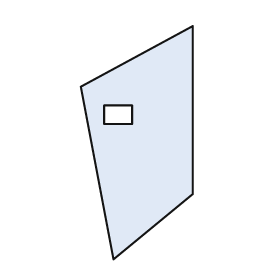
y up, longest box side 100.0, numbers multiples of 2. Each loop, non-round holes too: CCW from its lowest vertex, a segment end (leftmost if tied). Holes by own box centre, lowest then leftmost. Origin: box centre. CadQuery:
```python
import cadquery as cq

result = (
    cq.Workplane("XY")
    .moveTo(-10.0, -50.0)
    .lineTo(24.0, -22.0)
    .lineTo(24.0, 50.0)
    .lineTo(-24.0, 24.0)
    .close()
    .moveTo(-14.0, 8.0)
    .lineTo(-2.0, 8.0)
    .lineTo(-2.0, 16.0)
    .lineTo(-14.0, 16.0)
    .close()
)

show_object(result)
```